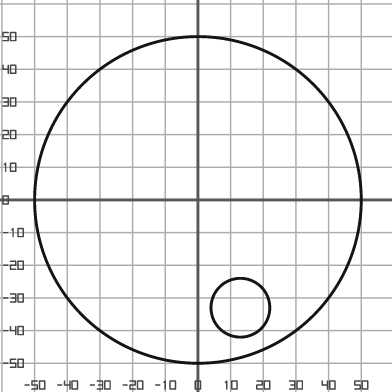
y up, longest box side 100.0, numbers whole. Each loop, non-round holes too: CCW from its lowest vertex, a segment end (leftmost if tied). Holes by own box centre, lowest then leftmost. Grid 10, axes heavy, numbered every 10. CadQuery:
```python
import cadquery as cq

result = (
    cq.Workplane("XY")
    .moveTo(0.0, 0.0)
    .circle(50.0)
    .moveTo(13.0, -33.0)
    .circle(9.0)
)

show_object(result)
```